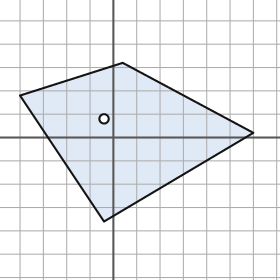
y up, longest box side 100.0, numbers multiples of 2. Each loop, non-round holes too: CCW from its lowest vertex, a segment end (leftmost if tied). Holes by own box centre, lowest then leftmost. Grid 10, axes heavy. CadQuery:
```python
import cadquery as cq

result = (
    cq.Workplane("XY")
    .moveTo(-4.0, -36.0)
    .lineTo(60.0, 2.0)
    .lineTo(4.0, 32.0)
    .lineTo(-40.0, 18.0)
    .close()
    .moveTo(-4.0, 8.0)
    .circle(2.0)
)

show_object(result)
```